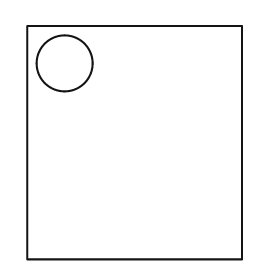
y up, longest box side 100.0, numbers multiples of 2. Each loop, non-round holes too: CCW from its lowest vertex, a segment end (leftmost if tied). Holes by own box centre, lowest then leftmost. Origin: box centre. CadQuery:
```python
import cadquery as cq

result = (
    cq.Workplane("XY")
    .moveTo(-46.0, -50.0)
    .lineTo(46.0, -50.0)
    .lineTo(46.0, 50.0)
    .lineTo(-46.0, 50.0)
    .close()
    .moveTo(-30.0, 34.0)
    .circle(12.0)
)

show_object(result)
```